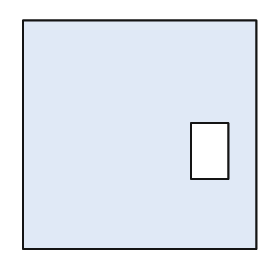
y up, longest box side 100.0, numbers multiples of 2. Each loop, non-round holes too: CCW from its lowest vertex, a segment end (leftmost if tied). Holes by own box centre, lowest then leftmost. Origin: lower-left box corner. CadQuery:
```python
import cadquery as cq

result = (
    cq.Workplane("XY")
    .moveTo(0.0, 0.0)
    .lineTo(100.0, 0.0)
    .lineTo(100.0, 98.0)
    .lineTo(0.0, 98.0)
    .close()
    .moveTo(72.0, 30.0)
    .lineTo(88.0, 30.0)
    .lineTo(88.0, 54.0)
    .lineTo(72.0, 54.0)
    .close()
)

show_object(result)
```